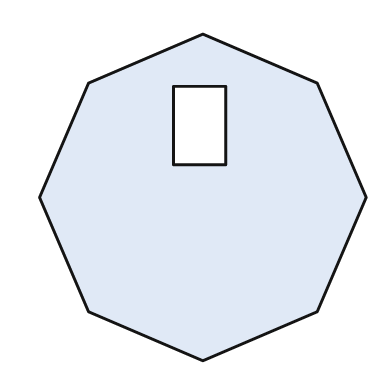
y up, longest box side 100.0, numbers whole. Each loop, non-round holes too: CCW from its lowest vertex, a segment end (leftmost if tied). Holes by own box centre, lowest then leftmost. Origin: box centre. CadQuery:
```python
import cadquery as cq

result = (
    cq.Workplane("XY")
    .moveTo(0.0, -50.0)
    .lineTo(35.0, -35.0)
    .lineTo(50.0, 0.0)
    .lineTo(35.0, 35.0)
    .lineTo(0.0, 50.0)
    .lineTo(-35.0, 35.0)
    .lineTo(-50.0, 0.0)
    .lineTo(-35.0, -35.0)
    .close()
    .moveTo(-9.0, 10.0)
    .lineTo(7.0, 10.0)
    .lineTo(7.0, 34.0)
    .lineTo(-9.0, 34.0)
    .close()
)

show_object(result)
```